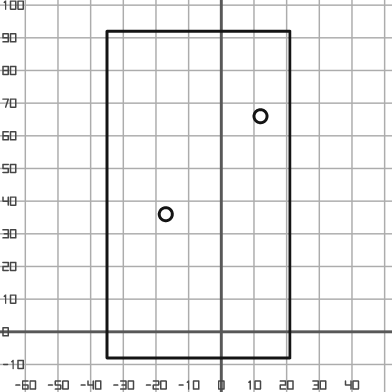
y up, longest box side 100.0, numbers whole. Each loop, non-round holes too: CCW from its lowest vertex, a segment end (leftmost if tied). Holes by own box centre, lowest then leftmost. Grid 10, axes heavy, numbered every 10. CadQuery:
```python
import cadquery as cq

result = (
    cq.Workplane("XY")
    .moveTo(-35.0, -8.0)
    .lineTo(21.0, -8.0)
    .lineTo(21.0, 92.0)
    .lineTo(-35.0, 92.0)
    .close()
    .moveTo(-17.0, 36.0)
    .circle(2.0)
    .moveTo(12.0, 66.0)
    .circle(2.0)
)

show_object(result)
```